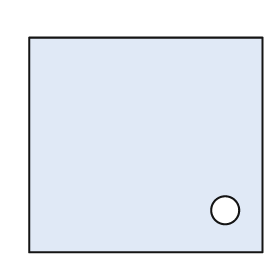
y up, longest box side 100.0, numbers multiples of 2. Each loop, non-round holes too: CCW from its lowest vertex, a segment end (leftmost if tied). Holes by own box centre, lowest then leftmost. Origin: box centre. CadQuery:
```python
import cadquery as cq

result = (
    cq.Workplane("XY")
    .moveTo(-50.0, -46.0)
    .lineTo(50.0, -46.0)
    .lineTo(50.0, 46.0)
    .lineTo(-50.0, 46.0)
    .close()
    .moveTo(34.0, -28.0)
    .circle(6.0)
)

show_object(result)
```